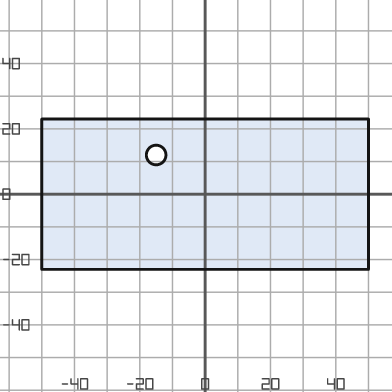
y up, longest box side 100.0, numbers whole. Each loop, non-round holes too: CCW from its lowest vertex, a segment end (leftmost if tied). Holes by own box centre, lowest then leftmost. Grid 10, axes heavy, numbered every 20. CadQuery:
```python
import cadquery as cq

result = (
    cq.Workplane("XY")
    .moveTo(-50.0, -23.0)
    .lineTo(50.0, -23.0)
    .lineTo(50.0, 23.0)
    .lineTo(-50.0, 23.0)
    .close()
    .moveTo(-15.0, 12.0)
    .circle(3.0)
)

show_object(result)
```